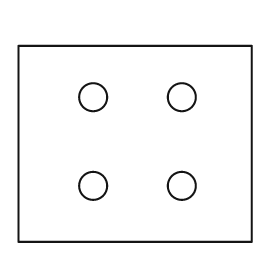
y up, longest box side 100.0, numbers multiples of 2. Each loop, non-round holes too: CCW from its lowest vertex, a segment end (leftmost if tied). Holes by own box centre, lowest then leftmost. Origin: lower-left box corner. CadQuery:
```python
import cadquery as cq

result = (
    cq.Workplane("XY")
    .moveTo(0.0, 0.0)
    .lineTo(100.0, 0.0)
    .lineTo(100.0, 84.0)
    .lineTo(0.0, 84.0)
    .close()
    .moveTo(32.0, 24.0)
    .circle(6.0)
    .moveTo(70.0, 24.0)
    .circle(6.0)
    .moveTo(32.0, 62.0)
    .circle(6.0)
    .moveTo(70.0, 62.0)
    .circle(6.0)
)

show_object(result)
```